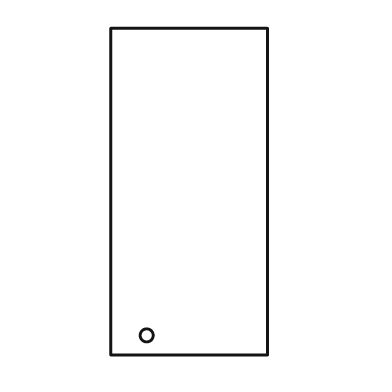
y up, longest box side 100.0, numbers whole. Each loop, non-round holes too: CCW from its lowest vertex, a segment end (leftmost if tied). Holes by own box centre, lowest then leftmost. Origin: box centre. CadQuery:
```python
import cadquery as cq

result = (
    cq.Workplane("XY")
    .moveTo(-24.0, -50.0)
    .lineTo(24.0, -50.0)
    .lineTo(24.0, 50.0)
    .lineTo(-24.0, 50.0)
    .close()
    .moveTo(-13.0, -44.0)
    .circle(2.0)
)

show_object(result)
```